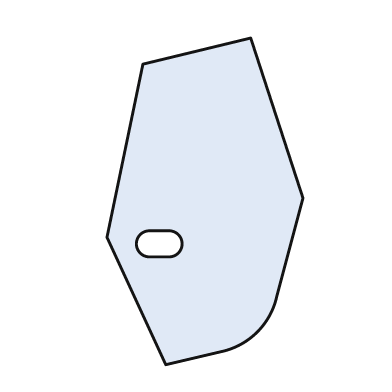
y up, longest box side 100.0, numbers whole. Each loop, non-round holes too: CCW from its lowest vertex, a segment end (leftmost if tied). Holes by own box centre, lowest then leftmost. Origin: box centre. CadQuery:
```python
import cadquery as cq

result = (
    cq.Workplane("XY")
    .moveTo(-12.0, -50.0)
    .lineTo(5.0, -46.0)
    .threePointArc((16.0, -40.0), (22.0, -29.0))
    .lineTo(30.0, 1.0)
    .lineTo(14.0, 50.0)
    .lineTo(-19.0, 42.0)
    .lineTo(-30.0, -11.0)
    .close()
    .moveTo(-17.0, -17.0)
    .lineTo(-11.0, -17.0)
    .threePointArc((-7.0, -13.0), (-11.0, -9.0))
    .lineTo(-17.0, -9.0)
    .threePointArc((-21.0, -13.0), (-17.0, -17.0))
    .close()
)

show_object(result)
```